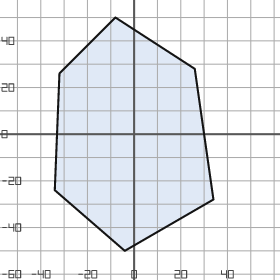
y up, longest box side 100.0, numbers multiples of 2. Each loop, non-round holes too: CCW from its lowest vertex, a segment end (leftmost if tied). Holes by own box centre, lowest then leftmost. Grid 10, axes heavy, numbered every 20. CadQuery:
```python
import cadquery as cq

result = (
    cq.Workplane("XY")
    .moveTo(-4.0, -50.0)
    .lineTo(34.0, -28.0)
    .lineTo(26.0, 28.0)
    .lineTo(-8.0, 50.0)
    .lineTo(-32.0, 26.0)
    .lineTo(-34.0, -24.0)
    .close()
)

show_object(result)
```